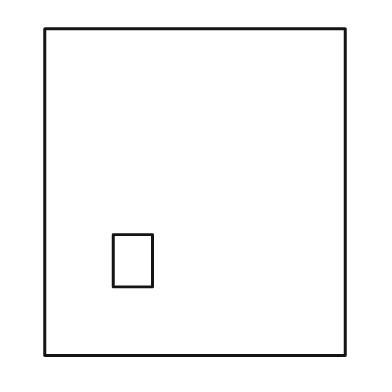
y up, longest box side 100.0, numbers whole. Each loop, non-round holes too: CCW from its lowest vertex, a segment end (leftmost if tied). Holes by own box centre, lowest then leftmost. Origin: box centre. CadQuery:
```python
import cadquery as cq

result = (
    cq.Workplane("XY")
    .moveTo(-46.0, -50.0)
    .lineTo(46.0, -50.0)
    .lineTo(46.0, 50.0)
    .lineTo(-46.0, 50.0)
    .close()
    .moveTo(-25.0, -29.0)
    .lineTo(-13.0, -29.0)
    .lineTo(-13.0, -13.0)
    .lineTo(-25.0, -13.0)
    .close()
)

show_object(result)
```